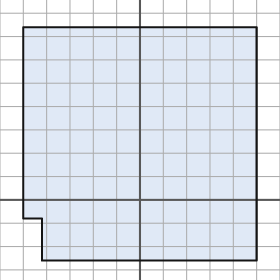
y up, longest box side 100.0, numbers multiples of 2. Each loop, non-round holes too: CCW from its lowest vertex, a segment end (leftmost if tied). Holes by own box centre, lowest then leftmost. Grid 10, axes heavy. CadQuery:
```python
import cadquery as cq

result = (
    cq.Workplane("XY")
    .moveTo(-42.0, -26.0)
    .lineTo(50.0, -26.0)
    .lineTo(50.0, 74.0)
    .lineTo(-50.0, 74.0)
    .lineTo(-50.0, -8.0)
    .lineTo(-42.0, -8.0)
    .close()
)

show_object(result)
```